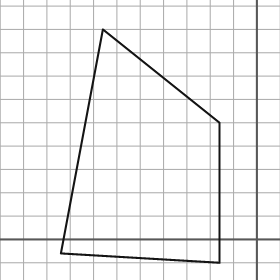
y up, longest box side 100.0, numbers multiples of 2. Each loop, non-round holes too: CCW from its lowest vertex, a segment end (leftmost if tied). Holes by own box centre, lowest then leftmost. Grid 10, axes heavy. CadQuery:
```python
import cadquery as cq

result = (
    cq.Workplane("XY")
    .moveTo(-16.0, -10.0)
    .lineTo(-16.0, 50.0)
    .lineTo(-66.0, 90.0)
    .lineTo(-84.0, -6.0)
    .close()
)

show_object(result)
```